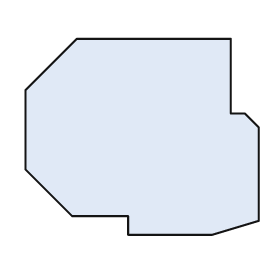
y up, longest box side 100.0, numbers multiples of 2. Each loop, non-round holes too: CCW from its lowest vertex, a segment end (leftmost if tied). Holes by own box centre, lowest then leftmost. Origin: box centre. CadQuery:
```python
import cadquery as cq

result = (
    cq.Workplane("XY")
    .moveTo(-6.0, -42.0)
    .lineTo(30.0, -42.0)
    .lineTo(50.0, -36.0)
    .lineTo(50.0, 4.0)
    .lineTo(44.0, 10.0)
    .lineTo(38.0, 10.0)
    .lineTo(38.0, 42.0)
    .lineTo(-28.0, 42.0)
    .lineTo(-50.0, 20.0)
    .lineTo(-50.0, -14.0)
    .lineTo(-30.0, -34.0)
    .lineTo(-6.0, -34.0)
    .close()
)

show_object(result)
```